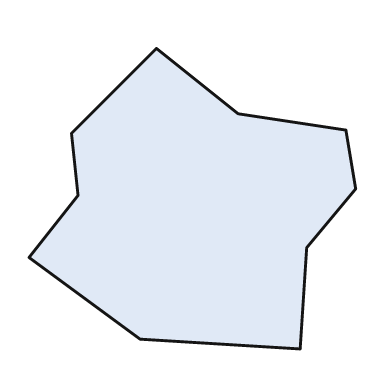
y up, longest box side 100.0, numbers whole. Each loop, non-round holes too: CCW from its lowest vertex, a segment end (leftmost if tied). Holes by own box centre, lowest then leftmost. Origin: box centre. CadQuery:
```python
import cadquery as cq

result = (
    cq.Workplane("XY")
    .moveTo(33.0, -46.0)
    .lineTo(35.0, -15.0)
    .lineTo(50.0, 3.0)
    .lineTo(47.0, 21.0)
    .lineTo(14.0, 26.0)
    .lineTo(-11.0, 46.0)
    .lineTo(-37.0, 20.0)
    .lineTo(-35.0, 1.0)
    .lineTo(-50.0, -18.0)
    .lineTo(-16.0, -43.0)
    .close()
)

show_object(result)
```